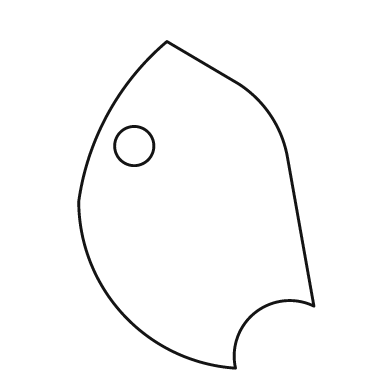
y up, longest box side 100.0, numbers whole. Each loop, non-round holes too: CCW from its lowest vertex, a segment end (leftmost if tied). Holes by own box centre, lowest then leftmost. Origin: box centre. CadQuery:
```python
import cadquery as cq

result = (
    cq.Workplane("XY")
    .moveTo(12.0, -50.0)
    .threePointArc((18.0, -33.0), (36.0, -31.0))
    .lineTo(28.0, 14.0)
    .threePointArc((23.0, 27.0), (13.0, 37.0))
    .lineTo(-9.0, 50.0)
    .threePointArc((-27.0, 28.0), (-36.0, 1.0))
    .threePointArc((-22.0, -34.0), (12.0, -50.0))
    .close()
    .moveTo(-19.0, 18.0)
    .circle(6.0)
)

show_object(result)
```